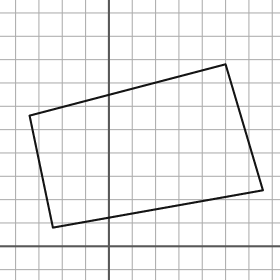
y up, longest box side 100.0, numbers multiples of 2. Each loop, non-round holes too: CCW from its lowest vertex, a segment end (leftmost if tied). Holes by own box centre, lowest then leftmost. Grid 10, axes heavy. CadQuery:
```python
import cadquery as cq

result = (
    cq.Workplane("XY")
    .moveTo(-24.0, 8.0)
    .lineTo(66.0, 24.0)
    .lineTo(50.0, 78.0)
    .lineTo(-34.0, 56.0)
    .close()
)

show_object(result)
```